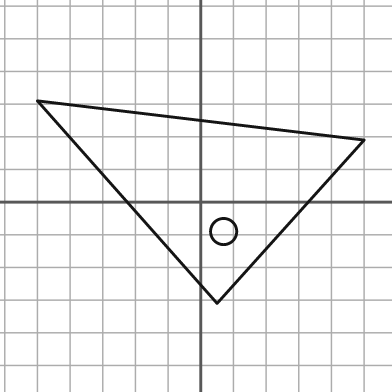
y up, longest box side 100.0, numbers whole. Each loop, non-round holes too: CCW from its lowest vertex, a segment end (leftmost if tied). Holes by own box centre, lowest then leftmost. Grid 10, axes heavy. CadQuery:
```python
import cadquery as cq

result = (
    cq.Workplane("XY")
    .moveTo(5.0, -31.0)
    .lineTo(50.0, 19.0)
    .lineTo(-50.0, 31.0)
    .close()
    .moveTo(7.0, -9.0)
    .circle(4.0)
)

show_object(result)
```